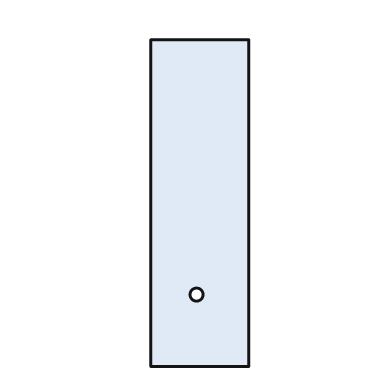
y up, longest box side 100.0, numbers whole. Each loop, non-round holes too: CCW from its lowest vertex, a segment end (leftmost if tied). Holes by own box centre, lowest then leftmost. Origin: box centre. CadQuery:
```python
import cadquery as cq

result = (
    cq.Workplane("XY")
    .moveTo(-15.0, -50.0)
    .lineTo(15.0, -50.0)
    .lineTo(15.0, 50.0)
    .lineTo(-15.0, 50.0)
    .close()
    .moveTo(-1.0, -28.0)
    .circle(2.0)
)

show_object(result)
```